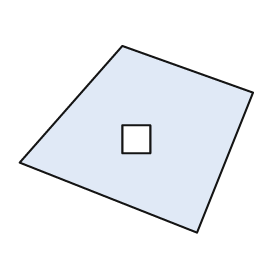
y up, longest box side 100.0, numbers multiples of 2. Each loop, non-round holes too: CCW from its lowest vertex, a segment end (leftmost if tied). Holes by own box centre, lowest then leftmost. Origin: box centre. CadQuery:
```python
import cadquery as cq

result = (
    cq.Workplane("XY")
    .moveTo(26.0, -40.0)
    .lineTo(50.0, 20.0)
    .lineTo(-6.0, 40.0)
    .lineTo(-50.0, -10.0)
    .close()
    .moveTo(-6.0, -6.0)
    .lineTo(6.0, -6.0)
    .lineTo(6.0, 6.0)
    .lineTo(-6.0, 6.0)
    .close()
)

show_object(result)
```